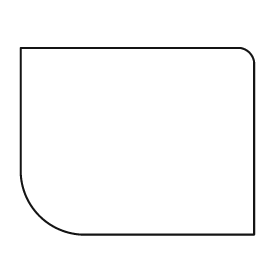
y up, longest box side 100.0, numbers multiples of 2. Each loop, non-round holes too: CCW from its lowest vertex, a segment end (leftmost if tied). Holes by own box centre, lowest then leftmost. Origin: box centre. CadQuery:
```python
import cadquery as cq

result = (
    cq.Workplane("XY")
    .moveTo(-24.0, -40.0)
    .lineTo(50.0, -40.0)
    .lineTo(50.0, 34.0)
    .threePointArc((48.0, 38.0), (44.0, 40.0))
    .lineTo(-50.0, 40.0)
    .lineTo(-50.0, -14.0)
    .threePointArc((-42.0, -32.0), (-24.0, -40.0))
    .close()
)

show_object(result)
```